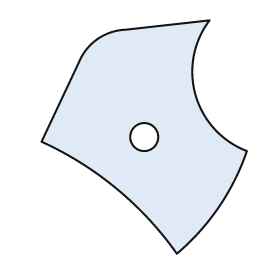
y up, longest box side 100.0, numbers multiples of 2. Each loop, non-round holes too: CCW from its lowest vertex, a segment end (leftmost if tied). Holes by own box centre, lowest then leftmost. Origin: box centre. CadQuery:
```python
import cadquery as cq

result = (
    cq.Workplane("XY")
    .moveTo(14.0, -50.0)
    .threePointArc((32.0, -30.0), (44.0, -6.0))
    .threePointArc((22.0, 18.0), (28.0, 50.0))
    .lineTo(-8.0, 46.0)
    .threePointArc((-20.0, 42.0), (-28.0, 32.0))
    .lineTo(-44.0, -2.0)
    .threePointArc((-12.0, -22.0), (14.0, -50.0))
    .close()
    .moveTo(0.0, 0.0)
    .circle(6.0)
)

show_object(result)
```